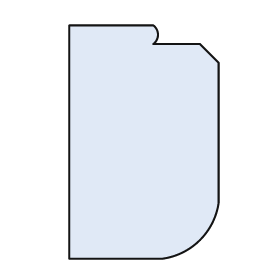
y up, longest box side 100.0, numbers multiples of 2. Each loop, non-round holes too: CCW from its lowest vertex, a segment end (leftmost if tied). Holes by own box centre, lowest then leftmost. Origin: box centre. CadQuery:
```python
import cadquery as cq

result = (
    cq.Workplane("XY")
    .moveTo(-32.0, -50.0)
    .lineTo(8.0, -50.0)
    .threePointArc((24.0, -42.0), (32.0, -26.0))
    .lineTo(32.0, 34.0)
    .lineTo(24.0, 42.0)
    .lineTo(4.0, 42.0)
    .threePointArc((6.0, 46.0), (4.0, 50.0))
    .lineTo(-32.0, 50.0)
    .close()
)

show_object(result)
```